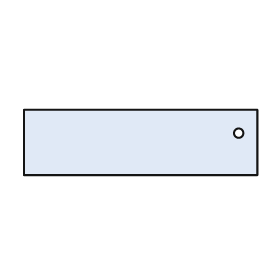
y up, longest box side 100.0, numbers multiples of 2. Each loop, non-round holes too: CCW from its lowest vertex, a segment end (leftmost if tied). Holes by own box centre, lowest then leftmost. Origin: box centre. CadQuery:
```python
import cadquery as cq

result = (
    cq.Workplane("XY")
    .moveTo(-50.0, -14.0)
    .lineTo(50.0, -14.0)
    .lineTo(50.0, 14.0)
    .lineTo(-50.0, 14.0)
    .close()
    .moveTo(42.0, 4.0)
    .circle(2.0)
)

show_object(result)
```